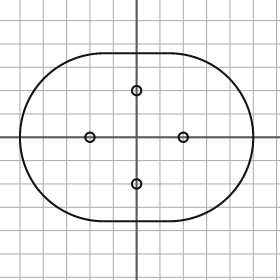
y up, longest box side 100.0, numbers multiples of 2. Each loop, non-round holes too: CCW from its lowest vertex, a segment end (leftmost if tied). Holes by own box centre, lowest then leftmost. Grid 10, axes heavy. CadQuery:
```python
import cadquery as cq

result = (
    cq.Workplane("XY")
    .moveTo(-14.0, -36.0)
    .lineTo(14.0, -36.0)
    .threePointArc((50.0, 0.0), (14.0, 36.0))
    .lineTo(-14.0, 36.0)
    .threePointArc((-50.0, 0.0), (-14.0, -36.0))
    .close()
    .moveTo(0.0, -20.0)
    .circle(2.0)
    .moveTo(-20.0, 0.0)
    .circle(2.0)
    .moveTo(20.0, 0.0)
    .circle(2.0)
    .moveTo(0.0, 20.0)
    .circle(2.0)
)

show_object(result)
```